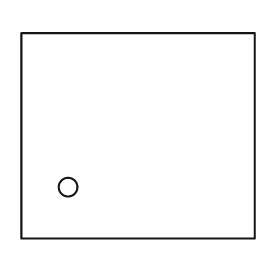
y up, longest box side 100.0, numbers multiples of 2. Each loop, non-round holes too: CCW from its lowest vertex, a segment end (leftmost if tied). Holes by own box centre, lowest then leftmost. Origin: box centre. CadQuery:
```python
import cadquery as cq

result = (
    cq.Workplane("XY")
    .moveTo(-50.0, -44.0)
    .lineTo(50.0, -44.0)
    .lineTo(50.0, 44.0)
    .lineTo(-50.0, 44.0)
    .close()
    .moveTo(-30.0, -22.0)
    .circle(4.0)
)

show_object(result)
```